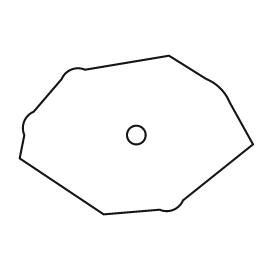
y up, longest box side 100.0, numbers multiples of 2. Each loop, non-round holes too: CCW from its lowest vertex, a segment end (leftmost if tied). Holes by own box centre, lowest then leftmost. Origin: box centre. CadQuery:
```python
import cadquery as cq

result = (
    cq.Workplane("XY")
    .moveTo(-14.0, -34.0)
    .lineTo(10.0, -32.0)
    .threePointArc((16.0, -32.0), (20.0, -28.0))
    .lineTo(50.0, -4.0)
    .lineTo(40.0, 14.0)
    .threePointArc((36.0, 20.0), (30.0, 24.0))
    .lineTo(14.0, 34.0)
    .lineTo(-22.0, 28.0)
    .threePointArc((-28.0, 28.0), (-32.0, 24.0))
    .lineTo(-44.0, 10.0)
    .threePointArc((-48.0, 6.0), (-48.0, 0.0))
    .lineTo(-50.0, -10.0)
    .close()
    .moveTo(0.0, 0.0)
    .circle(4.0)
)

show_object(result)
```